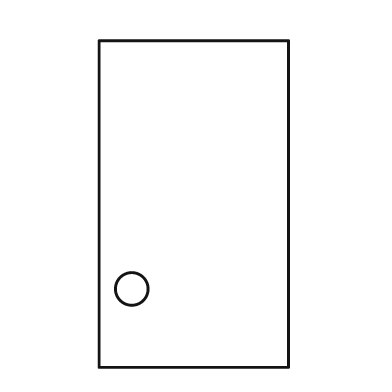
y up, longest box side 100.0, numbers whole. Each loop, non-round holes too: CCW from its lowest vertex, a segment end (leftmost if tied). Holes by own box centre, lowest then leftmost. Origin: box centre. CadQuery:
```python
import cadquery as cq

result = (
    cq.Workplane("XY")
    .moveTo(-29.0, -50.0)
    .lineTo(29.0, -50.0)
    .lineTo(29.0, 50.0)
    .lineTo(-29.0, 50.0)
    .close()
    .moveTo(-19.0, -26.0)
    .circle(5.0)
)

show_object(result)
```